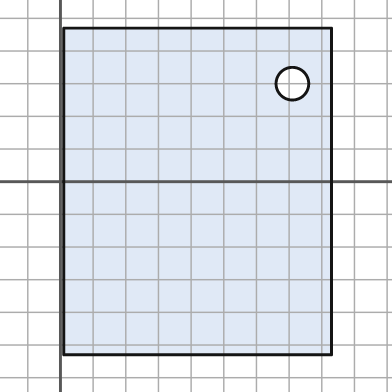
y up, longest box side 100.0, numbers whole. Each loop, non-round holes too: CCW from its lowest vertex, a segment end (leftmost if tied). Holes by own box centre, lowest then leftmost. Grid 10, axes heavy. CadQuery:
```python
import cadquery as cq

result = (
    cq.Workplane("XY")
    .moveTo(1.0, -53.0)
    .lineTo(83.0, -53.0)
    .lineTo(83.0, 47.0)
    .lineTo(1.0, 47.0)
    .close()
    .moveTo(71.0, 30.0)
    .circle(5.0)
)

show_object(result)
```